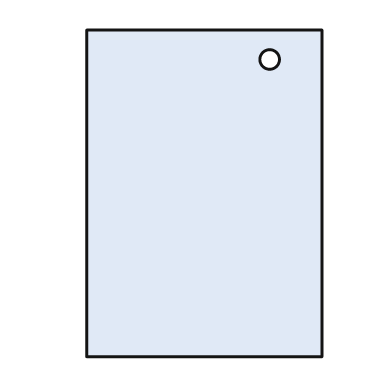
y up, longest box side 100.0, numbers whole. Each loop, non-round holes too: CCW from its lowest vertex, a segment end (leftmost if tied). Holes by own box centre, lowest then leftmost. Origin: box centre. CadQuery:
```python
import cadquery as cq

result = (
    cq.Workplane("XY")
    .moveTo(-36.0, -50.0)
    .lineTo(36.0, -50.0)
    .lineTo(36.0, 50.0)
    .lineTo(-36.0, 50.0)
    .close()
    .moveTo(20.0, 41.0)
    .circle(3.0)
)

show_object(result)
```